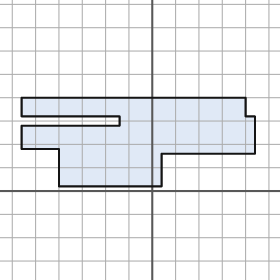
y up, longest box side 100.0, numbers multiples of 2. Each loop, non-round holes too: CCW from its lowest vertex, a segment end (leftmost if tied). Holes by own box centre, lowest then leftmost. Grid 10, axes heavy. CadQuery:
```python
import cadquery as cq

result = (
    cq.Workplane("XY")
    .moveTo(-40.0, 2.0)
    .lineTo(4.0, 2.0)
    .lineTo(4.0, 16.0)
    .lineTo(44.0, 16.0)
    .lineTo(44.0, 32.0)
    .lineTo(40.0, 32.0)
    .lineTo(40.0, 40.0)
    .lineTo(-56.0, 40.0)
    .lineTo(-56.0, 32.0)
    .lineTo(-14.0, 32.0)
    .lineTo(-14.0, 28.0)
    .lineTo(-56.0, 28.0)
    .lineTo(-56.0, 18.0)
    .lineTo(-40.0, 18.0)
    .close()
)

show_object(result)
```